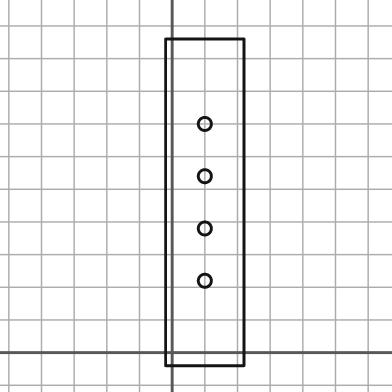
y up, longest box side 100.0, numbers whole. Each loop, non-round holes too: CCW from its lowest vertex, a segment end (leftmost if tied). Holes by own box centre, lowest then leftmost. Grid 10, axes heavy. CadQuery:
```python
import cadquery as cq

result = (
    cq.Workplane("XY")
    .moveTo(-2.0, -4.0)
    .lineTo(22.0, -4.0)
    .lineTo(22.0, 96.0)
    .lineTo(-2.0, 96.0)
    .close()
    .moveTo(10.0, 22.0)
    .circle(2.0)
    .moveTo(10.0, 38.0)
    .circle(2.0)
    .moveTo(10.0, 54.0)
    .circle(2.0)
    .moveTo(10.0, 70.0)
    .circle(2.0)
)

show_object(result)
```